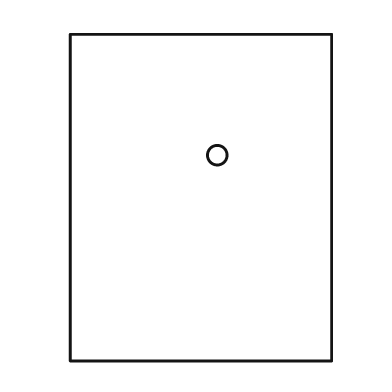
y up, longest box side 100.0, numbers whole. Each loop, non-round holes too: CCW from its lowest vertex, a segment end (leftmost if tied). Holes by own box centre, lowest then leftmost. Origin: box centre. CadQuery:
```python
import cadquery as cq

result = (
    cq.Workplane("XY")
    .moveTo(-40.0, -50.0)
    .lineTo(40.0, -50.0)
    .lineTo(40.0, 50.0)
    .lineTo(-40.0, 50.0)
    .close()
    .moveTo(5.0, 13.0)
    .circle(3.0)
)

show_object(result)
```